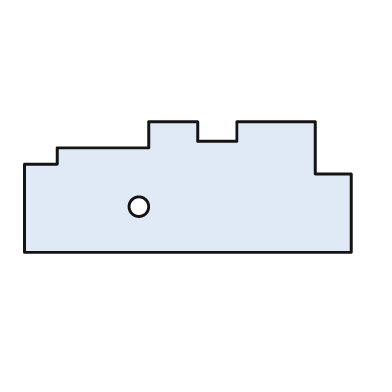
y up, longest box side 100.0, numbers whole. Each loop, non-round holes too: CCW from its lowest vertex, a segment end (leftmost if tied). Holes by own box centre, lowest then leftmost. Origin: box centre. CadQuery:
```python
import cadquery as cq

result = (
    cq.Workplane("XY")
    .moveTo(-50.0, -20.0)
    .lineTo(50.0, -20.0)
    .lineTo(50.0, 4.0)
    .lineTo(39.0, 4.0)
    .lineTo(39.0, 20.0)
    .lineTo(15.0, 20.0)
    .lineTo(15.0, 14.0)
    .lineTo(3.0, 14.0)
    .lineTo(3.0, 20.0)
    .lineTo(-12.0, 20.0)
    .lineTo(-12.0, 12.0)
    .lineTo(-40.0, 12.0)
    .lineTo(-40.0, 7.0)
    .lineTo(-50.0, 7.0)
    .close()
    .moveTo(-15.0, -6.0)
    .circle(3.0)
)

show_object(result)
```